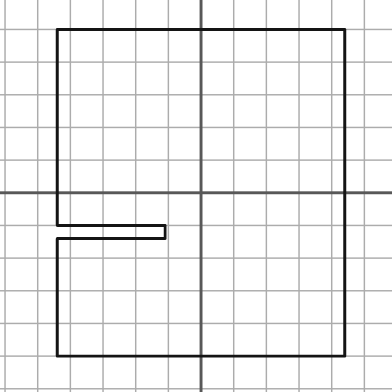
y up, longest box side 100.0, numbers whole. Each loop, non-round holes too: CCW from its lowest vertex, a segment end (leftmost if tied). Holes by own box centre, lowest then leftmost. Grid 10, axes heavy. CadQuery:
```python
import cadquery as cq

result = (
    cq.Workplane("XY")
    .moveTo(-44.0, -50.0)
    .lineTo(44.0, -50.0)
    .lineTo(44.0, 50.0)
    .lineTo(-44.0, 50.0)
    .lineTo(-44.0, -10.0)
    .lineTo(-11.0, -10.0)
    .lineTo(-11.0, -14.0)
    .lineTo(-44.0, -14.0)
    .close()
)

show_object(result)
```